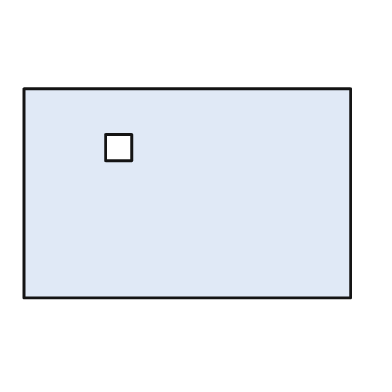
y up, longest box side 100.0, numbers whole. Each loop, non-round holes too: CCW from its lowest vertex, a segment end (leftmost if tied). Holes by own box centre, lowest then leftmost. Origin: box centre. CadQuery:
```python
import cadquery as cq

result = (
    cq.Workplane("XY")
    .moveTo(-50.0, -32.0)
    .lineTo(50.0, -32.0)
    .lineTo(50.0, 32.0)
    .lineTo(-50.0, 32.0)
    .close()
    .moveTo(-25.0, 10.0)
    .lineTo(-17.0, 10.0)
    .lineTo(-17.0, 18.0)
    .lineTo(-25.0, 18.0)
    .close()
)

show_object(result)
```